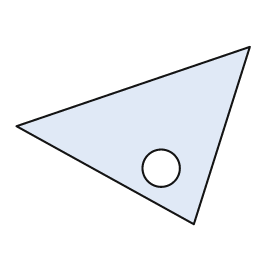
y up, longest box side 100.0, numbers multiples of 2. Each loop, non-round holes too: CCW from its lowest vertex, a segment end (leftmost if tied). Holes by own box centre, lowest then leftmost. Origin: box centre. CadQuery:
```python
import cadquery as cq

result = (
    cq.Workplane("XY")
    .moveTo(26.0, -38.0)
    .lineTo(50.0, 38.0)
    .lineTo(-50.0, 4.0)
    .close()
    .moveTo(12.0, -14.0)
    .circle(8.0)
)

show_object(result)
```